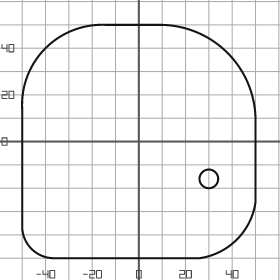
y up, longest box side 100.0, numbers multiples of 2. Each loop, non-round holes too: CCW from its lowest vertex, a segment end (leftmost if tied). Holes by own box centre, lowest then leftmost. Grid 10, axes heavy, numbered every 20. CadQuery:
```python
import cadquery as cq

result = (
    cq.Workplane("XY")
    .moveTo(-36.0, -50.0)
    .lineTo(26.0, -50.0)
    .threePointArc((42.0, -42.0), (50.0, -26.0))
    .lineTo(50.0, 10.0)
    .threePointArc((38.0, 38.0), (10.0, 50.0))
    .lineTo(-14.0, 50.0)
    .threePointArc((-40.0, 40.0), (-50.0, 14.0))
    .lineTo(-50.0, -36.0)
    .threePointArc((-46.0, -46.0), (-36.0, -50.0))
    .close()
    .moveTo(30.0, -16.0)
    .circle(4.0)
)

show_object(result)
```